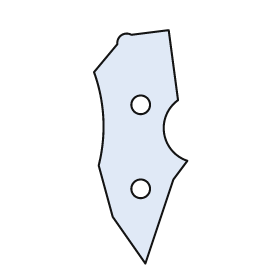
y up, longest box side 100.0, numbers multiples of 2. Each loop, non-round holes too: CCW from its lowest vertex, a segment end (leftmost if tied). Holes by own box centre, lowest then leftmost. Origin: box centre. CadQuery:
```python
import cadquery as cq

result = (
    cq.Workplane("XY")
    .moveTo(2.0, -50.0)
    .lineTo(14.0, -14.0)
    .lineTo(20.0, -6.0)
    .threePointArc((10.0, 6.0), (16.0, 20.0))
    .lineTo(12.0, 50.0)
    .lineTo(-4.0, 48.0)
    .threePointArc((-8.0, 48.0), (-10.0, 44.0))
    .lineTo(-20.0, 32.0)
    .threePointArc((-16.0, 12.0), (-18.0, -8.0))
    .lineTo(-12.0, -30.0)
    .close()
    .moveTo(0.0, -18.0)
    .circle(4.0)
    .moveTo(0.0, 18.0)
    .circle(4.0)
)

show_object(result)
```